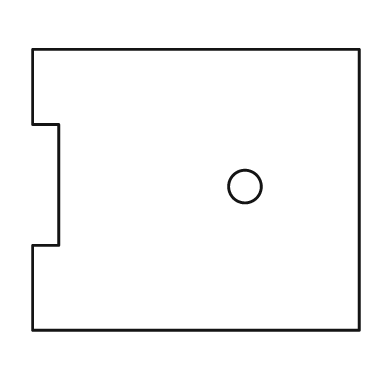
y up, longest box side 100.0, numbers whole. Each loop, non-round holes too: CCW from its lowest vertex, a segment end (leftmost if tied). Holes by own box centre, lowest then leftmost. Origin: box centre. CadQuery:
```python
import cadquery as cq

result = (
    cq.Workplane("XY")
    .moveTo(-50.0, -43.0)
    .lineTo(50.0, -43.0)
    .lineTo(50.0, 43.0)
    .lineTo(-50.0, 43.0)
    .lineTo(-50.0, 20.0)
    .lineTo(-42.0, 20.0)
    .lineTo(-42.0, -17.0)
    .lineTo(-50.0, -17.0)
    .close()
    .moveTo(15.0, 1.0)
    .circle(5.0)
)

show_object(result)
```